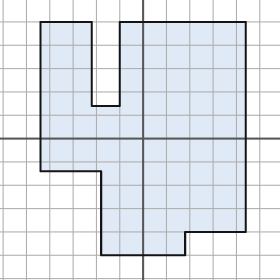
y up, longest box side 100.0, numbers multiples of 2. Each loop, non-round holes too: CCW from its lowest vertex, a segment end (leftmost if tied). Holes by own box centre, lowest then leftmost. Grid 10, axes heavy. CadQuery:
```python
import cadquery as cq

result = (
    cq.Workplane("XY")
    .moveTo(-18.0, -50.0)
    .lineTo(18.0, -50.0)
    .lineTo(18.0, -40.0)
    .lineTo(44.0, -40.0)
    .lineTo(44.0, 50.0)
    .lineTo(-10.0, 50.0)
    .lineTo(-10.0, 14.0)
    .lineTo(-22.0, 14.0)
    .lineTo(-22.0, 50.0)
    .lineTo(-44.0, 50.0)
    .lineTo(-44.0, -14.0)
    .lineTo(-18.0, -14.0)
    .close()
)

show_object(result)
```